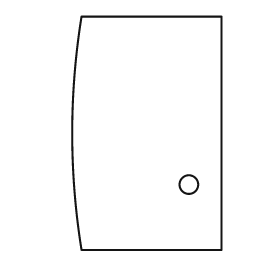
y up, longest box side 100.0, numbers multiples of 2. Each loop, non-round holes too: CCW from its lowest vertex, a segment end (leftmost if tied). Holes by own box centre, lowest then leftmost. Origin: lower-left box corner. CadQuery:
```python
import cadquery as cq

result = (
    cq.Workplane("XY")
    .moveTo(4.0, 0.0)
    .lineTo(64.0, 0.0)
    .lineTo(64.0, 100.0)
    .lineTo(4.0, 100.0)
    .threePointArc((0.0, 50.0), (4.0, 0.0))
    .close()
    .moveTo(50.0, 28.0)
    .circle(4.0)
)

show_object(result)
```